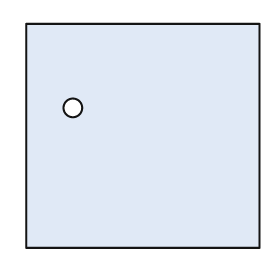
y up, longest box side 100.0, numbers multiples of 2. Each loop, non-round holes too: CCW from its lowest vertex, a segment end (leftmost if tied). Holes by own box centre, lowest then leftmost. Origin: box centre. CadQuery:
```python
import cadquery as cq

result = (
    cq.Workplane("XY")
    .moveTo(-50.0, -48.0)
    .lineTo(50.0, -48.0)
    .lineTo(50.0, 48.0)
    .lineTo(-50.0, 48.0)
    .close()
    .moveTo(-30.0, 12.0)
    .circle(4.0)
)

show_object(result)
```